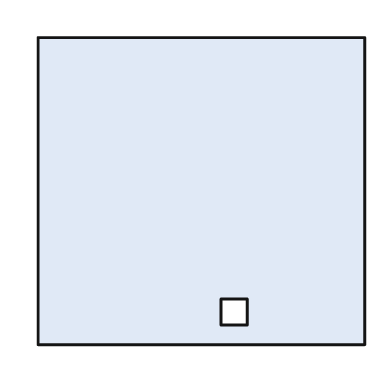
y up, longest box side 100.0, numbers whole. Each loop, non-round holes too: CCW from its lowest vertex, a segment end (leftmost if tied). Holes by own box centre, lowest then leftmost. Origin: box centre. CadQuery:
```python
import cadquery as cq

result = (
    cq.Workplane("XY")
    .moveTo(-50.0, -47.0)
    .lineTo(50.0, -47.0)
    .lineTo(50.0, 47.0)
    .lineTo(-50.0, 47.0)
    .close()
    .moveTo(6.0, -41.0)
    .lineTo(14.0, -41.0)
    .lineTo(14.0, -33.0)
    .lineTo(6.0, -33.0)
    .close()
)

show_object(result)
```